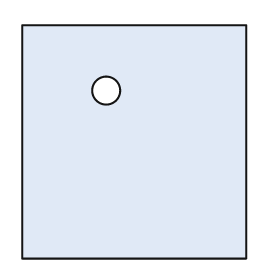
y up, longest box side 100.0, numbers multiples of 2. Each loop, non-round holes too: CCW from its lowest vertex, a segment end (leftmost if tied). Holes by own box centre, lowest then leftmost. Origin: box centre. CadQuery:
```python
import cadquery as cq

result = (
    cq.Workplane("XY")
    .moveTo(-48.0, -50.0)
    .lineTo(48.0, -50.0)
    .lineTo(48.0, 50.0)
    .lineTo(-48.0, 50.0)
    .close()
    .moveTo(-12.0, 22.0)
    .circle(6.0)
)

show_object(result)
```